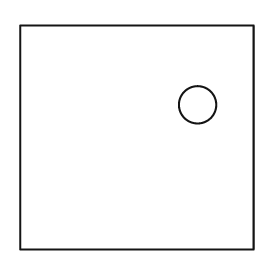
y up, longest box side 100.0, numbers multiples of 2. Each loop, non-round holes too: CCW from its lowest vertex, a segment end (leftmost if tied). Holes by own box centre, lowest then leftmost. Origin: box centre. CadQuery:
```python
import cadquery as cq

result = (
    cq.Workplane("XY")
    .moveTo(-50.0, -48.0)
    .lineTo(50.0, -48.0)
    .lineTo(50.0, 48.0)
    .lineTo(-50.0, 48.0)
    .close()
    .moveTo(26.0, 14.0)
    .circle(8.0)
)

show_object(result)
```